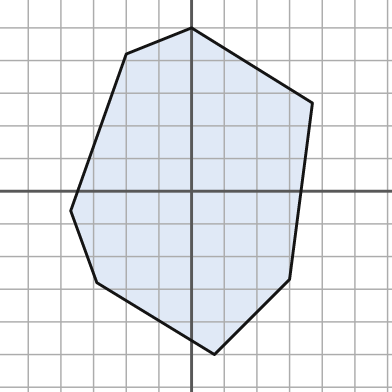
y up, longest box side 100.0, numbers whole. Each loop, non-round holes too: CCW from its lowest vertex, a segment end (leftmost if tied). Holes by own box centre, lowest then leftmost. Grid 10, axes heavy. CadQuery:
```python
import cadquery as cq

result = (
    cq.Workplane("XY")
    .moveTo(7.0, -50.0)
    .lineTo(30.0, -27.0)
    .lineTo(37.0, 27.0)
    .lineTo(0.0, 50.0)
    .lineTo(-20.0, 42.0)
    .lineTo(-37.0, -6.0)
    .lineTo(-29.0, -28.0)
    .close()
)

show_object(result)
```